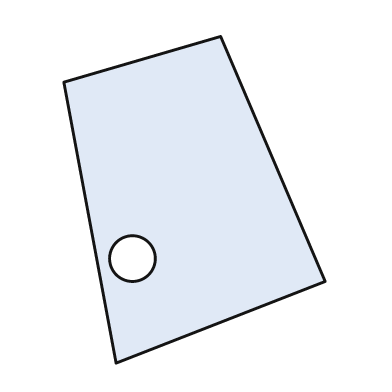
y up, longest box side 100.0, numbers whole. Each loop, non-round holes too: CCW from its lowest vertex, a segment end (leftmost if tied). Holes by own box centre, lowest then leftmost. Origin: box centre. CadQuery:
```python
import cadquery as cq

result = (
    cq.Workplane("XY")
    .moveTo(-24.0, -50.0)
    .lineTo(40.0, -25.0)
    .lineTo(8.0, 50.0)
    .lineTo(-40.0, 36.0)
    .close()
    .moveTo(-19.0, -18.0)
    .circle(7.0)
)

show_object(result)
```